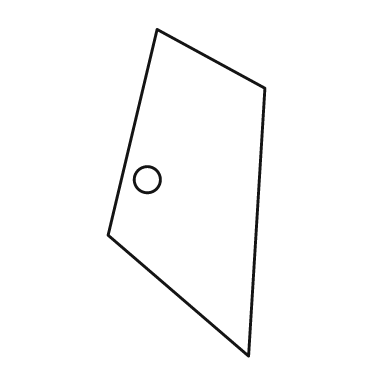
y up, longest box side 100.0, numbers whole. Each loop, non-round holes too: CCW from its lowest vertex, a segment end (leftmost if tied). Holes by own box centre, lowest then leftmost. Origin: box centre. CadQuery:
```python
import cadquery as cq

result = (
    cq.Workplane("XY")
    .moveTo(19.0, -50.0)
    .lineTo(24.0, 32.0)
    .lineTo(-9.0, 50.0)
    .lineTo(-24.0, -13.0)
    .close()
    .moveTo(-12.0, 4.0)
    .circle(4.0)
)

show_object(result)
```